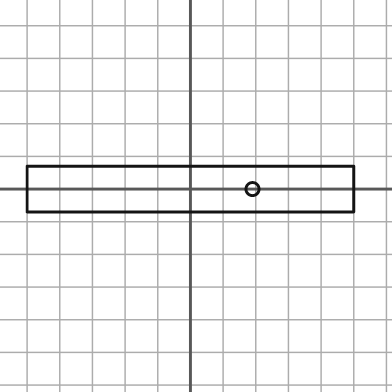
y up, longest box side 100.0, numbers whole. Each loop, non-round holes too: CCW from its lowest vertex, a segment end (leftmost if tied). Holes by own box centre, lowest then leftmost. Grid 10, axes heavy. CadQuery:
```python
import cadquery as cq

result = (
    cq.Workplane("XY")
    .moveTo(-50.0, -7.0)
    .lineTo(50.0, -7.0)
    .lineTo(50.0, 7.0)
    .lineTo(-50.0, 7.0)
    .close()
    .moveTo(19.0, 0.0)
    .circle(2.0)
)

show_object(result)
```